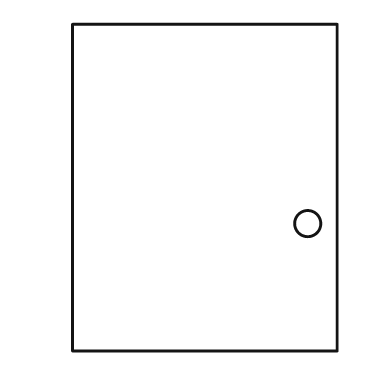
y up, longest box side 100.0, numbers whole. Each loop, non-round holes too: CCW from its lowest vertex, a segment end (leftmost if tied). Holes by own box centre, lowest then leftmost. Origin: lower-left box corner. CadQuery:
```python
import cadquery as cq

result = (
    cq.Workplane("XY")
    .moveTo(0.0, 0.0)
    .lineTo(81.0, 0.0)
    .lineTo(81.0, 100.0)
    .lineTo(0.0, 100.0)
    .close()
    .moveTo(72.0, 39.0)
    .circle(4.0)
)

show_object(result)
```